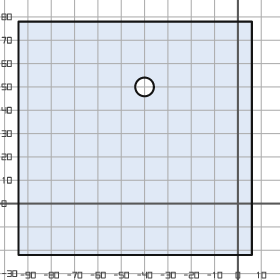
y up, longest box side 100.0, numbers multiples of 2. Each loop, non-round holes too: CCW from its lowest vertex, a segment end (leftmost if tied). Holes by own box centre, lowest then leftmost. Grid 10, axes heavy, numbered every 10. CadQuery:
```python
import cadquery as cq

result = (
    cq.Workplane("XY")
    .moveTo(-94.0, -22.0)
    .lineTo(6.0, -22.0)
    .lineTo(6.0, 78.0)
    .lineTo(-94.0, 78.0)
    .close()
    .moveTo(-40.0, 50.0)
    .circle(4.0)
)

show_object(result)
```